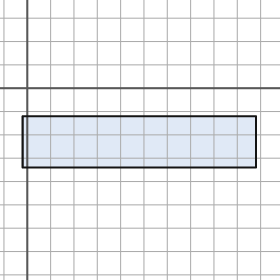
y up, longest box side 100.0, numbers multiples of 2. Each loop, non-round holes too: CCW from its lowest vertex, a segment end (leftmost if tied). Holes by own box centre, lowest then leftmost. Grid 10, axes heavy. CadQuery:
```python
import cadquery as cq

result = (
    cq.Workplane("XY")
    .moveTo(-2.0, -34.0)
    .lineTo(98.0, -34.0)
    .lineTo(98.0, -12.0)
    .lineTo(-2.0, -12.0)
    .close()
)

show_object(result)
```